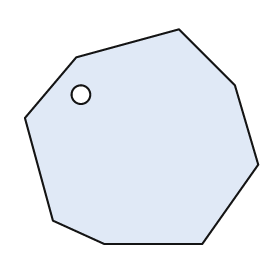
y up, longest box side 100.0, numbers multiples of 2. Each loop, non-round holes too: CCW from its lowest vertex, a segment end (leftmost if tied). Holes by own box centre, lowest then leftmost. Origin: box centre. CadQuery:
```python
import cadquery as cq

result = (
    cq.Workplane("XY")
    .moveTo(-16.0, -46.0)
    .lineTo(26.0, -46.0)
    .lineTo(50.0, -12.0)
    .lineTo(40.0, 22.0)
    .lineTo(16.0, 46.0)
    .lineTo(-28.0, 34.0)
    .lineTo(-50.0, 8.0)
    .lineTo(-38.0, -36.0)
    .close()
    .moveTo(-26.0, 18.0)
    .circle(4.0)
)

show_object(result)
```